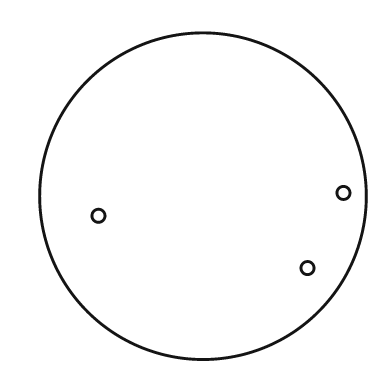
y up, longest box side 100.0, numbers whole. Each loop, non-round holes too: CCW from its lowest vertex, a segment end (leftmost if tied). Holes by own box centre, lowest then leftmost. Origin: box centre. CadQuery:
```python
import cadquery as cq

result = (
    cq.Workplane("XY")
    .moveTo(0.0, 0.0)
    .circle(50.0)
    .moveTo(32.0, -22.0)
    .circle(2.0)
    .moveTo(-32.0, -6.0)
    .circle(2.0)
    .moveTo(43.0, 1.0)
    .circle(2.0)
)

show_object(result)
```